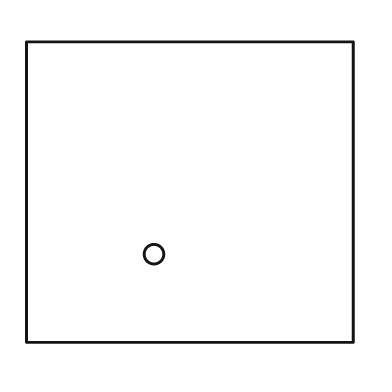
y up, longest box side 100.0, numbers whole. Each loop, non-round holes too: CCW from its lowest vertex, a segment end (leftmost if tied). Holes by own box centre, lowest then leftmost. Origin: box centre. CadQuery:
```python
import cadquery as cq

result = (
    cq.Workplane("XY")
    .moveTo(-50.0, -46.0)
    .lineTo(50.0, -46.0)
    .lineTo(50.0, 46.0)
    .lineTo(-50.0, 46.0)
    .close()
    .moveTo(-11.0, -19.0)
    .circle(3.0)
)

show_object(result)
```